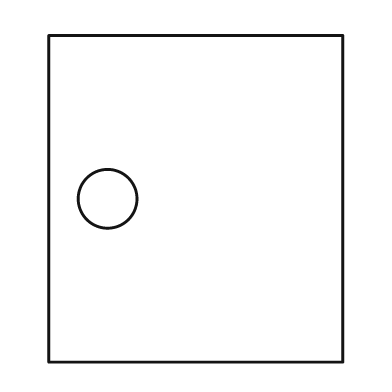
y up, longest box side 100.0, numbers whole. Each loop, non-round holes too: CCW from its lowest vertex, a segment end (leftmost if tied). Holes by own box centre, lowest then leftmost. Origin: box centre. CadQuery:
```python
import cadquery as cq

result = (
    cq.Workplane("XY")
    .moveTo(-45.0, -50.0)
    .lineTo(45.0, -50.0)
    .lineTo(45.0, 50.0)
    .lineTo(-45.0, 50.0)
    .close()
    .moveTo(-27.0, 0.0)
    .circle(9.0)
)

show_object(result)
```